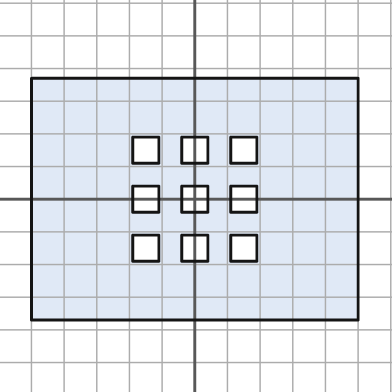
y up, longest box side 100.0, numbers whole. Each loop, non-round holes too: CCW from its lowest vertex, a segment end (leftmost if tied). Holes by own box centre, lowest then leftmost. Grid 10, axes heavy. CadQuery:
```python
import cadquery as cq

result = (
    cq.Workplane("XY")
    .moveTo(-50.0, -37.0)
    .lineTo(50.0, -37.0)
    .lineTo(50.0, 37.0)
    .lineTo(-50.0, 37.0)
    .close()
    .moveTo(-19.0, -19.0)
    .lineTo(-11.0, -19.0)
    .lineTo(-11.0, -11.0)
    .lineTo(-19.0, -11.0)
    .close()
    .moveTo(-4.0, -19.0)
    .lineTo(4.0, -19.0)
    .lineTo(4.0, -11.0)
    .lineTo(-4.0, -11.0)
    .close()
    .moveTo(11.0, -19.0)
    .lineTo(19.0, -19.0)
    .lineTo(19.0, -11.0)
    .lineTo(11.0, -11.0)
    .close()
    .moveTo(-19.0, -4.0)
    .lineTo(-11.0, -4.0)
    .lineTo(-11.0, 4.0)
    .lineTo(-19.0, 4.0)
    .close()
    .moveTo(-4.0, -4.0)
    .lineTo(4.0, -4.0)
    .lineTo(4.0, 4.0)
    .lineTo(-4.0, 4.0)
    .close()
    .moveTo(11.0, -4.0)
    .lineTo(19.0, -4.0)
    .lineTo(19.0, 4.0)
    .lineTo(11.0, 4.0)
    .close()
    .moveTo(-19.0, 11.0)
    .lineTo(-11.0, 11.0)
    .lineTo(-11.0, 19.0)
    .lineTo(-19.0, 19.0)
    .close()
    .moveTo(-4.0, 11.0)
    .lineTo(4.0, 11.0)
    .lineTo(4.0, 19.0)
    .lineTo(-4.0, 19.0)
    .close()
    .moveTo(11.0, 11.0)
    .lineTo(19.0, 11.0)
    .lineTo(19.0, 19.0)
    .lineTo(11.0, 19.0)
    .close()
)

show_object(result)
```